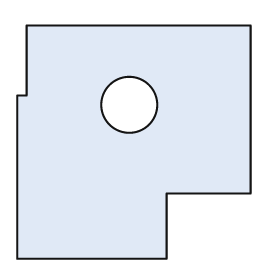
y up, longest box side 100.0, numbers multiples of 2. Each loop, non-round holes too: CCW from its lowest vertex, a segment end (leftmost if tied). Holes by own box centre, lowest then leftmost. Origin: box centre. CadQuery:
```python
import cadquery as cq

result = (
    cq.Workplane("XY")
    .moveTo(-50.0, -50.0)
    .lineTo(14.0, -50.0)
    .lineTo(14.0, -22.0)
    .lineTo(50.0, -22.0)
    .lineTo(50.0, 50.0)
    .lineTo(-46.0, 50.0)
    .lineTo(-46.0, 20.0)
    .lineTo(-50.0, 20.0)
    .close()
    .moveTo(-2.0, 16.0)
    .circle(12.0)
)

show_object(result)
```